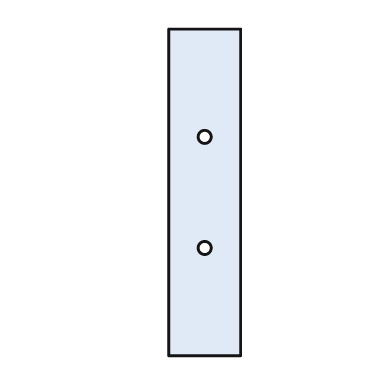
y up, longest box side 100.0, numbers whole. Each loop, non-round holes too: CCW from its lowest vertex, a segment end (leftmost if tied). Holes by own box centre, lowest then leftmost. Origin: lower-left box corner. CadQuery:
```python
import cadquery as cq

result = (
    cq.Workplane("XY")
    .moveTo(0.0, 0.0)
    .lineTo(22.0, 0.0)
    .lineTo(22.0, 100.0)
    .lineTo(0.0, 100.0)
    .close()
    .moveTo(11.0, 33.0)
    .circle(2.0)
    .moveTo(11.0, 67.0)
    .circle(2.0)
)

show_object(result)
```